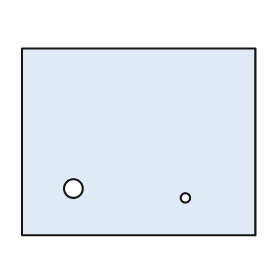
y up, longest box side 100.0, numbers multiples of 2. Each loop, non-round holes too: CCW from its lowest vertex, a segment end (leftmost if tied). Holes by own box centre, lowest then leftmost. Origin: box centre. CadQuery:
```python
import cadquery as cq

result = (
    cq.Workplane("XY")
    .moveTo(-50.0, -40.0)
    .lineTo(50.0, -40.0)
    .lineTo(50.0, 40.0)
    .lineTo(-50.0, 40.0)
    .close()
    .moveTo(20.0, -24.0)
    .circle(2.0)
    .moveTo(-28.0, -20.0)
    .circle(4.0)
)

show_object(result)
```